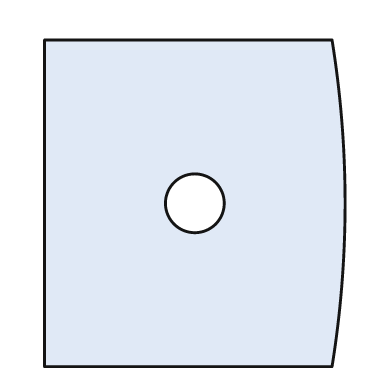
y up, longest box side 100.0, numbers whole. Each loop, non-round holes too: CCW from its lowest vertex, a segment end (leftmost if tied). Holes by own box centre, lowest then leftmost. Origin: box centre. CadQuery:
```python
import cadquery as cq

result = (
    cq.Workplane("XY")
    .moveTo(-46.0, -50.0)
    .lineTo(42.0, -50.0)
    .threePointArc((46.0, 0.0), (42.0, 50.0))
    .lineTo(-46.0, 50.0)
    .close()
    .moveTo(0.0, 0.0)
    .circle(9.0)
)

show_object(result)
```